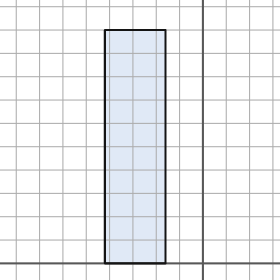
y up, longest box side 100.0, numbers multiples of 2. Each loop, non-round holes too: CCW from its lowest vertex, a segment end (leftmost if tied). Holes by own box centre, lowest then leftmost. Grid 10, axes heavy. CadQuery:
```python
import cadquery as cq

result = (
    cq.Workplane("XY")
    .moveTo(-42.0, 0.0)
    .lineTo(-16.0, 0.0)
    .lineTo(-16.0, 100.0)
    .lineTo(-42.0, 100.0)
    .close()
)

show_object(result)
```